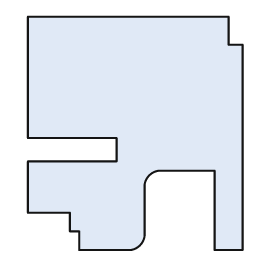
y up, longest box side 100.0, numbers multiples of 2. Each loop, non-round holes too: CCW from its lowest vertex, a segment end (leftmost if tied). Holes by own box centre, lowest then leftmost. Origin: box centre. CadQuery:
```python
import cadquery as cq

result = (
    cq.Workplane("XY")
    .moveTo(-24.0, -50.0)
    .lineTo(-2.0, -50.0)
    .threePointArc((2.0, -48.0), (4.0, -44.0))
    .lineTo(4.0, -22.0)
    .threePointArc((6.0, -18.0), (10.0, -16.0))
    .lineTo(34.0, -16.0)
    .lineTo(34.0, -50.0)
    .lineTo(46.0, -50.0)
    .lineTo(46.0, 38.0)
    .lineTo(40.0, 38.0)
    .lineTo(40.0, 50.0)
    .lineTo(-46.0, 50.0)
    .lineTo(-46.0, -2.0)
    .lineTo(-8.0, -2.0)
    .lineTo(-8.0, -12.0)
    .lineTo(-46.0, -12.0)
    .lineTo(-46.0, -34.0)
    .lineTo(-28.0, -34.0)
    .lineTo(-28.0, -42.0)
    .lineTo(-24.0, -42.0)
    .close()
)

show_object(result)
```